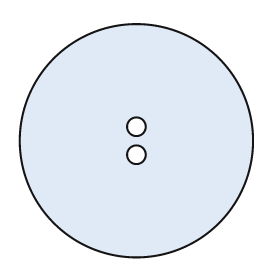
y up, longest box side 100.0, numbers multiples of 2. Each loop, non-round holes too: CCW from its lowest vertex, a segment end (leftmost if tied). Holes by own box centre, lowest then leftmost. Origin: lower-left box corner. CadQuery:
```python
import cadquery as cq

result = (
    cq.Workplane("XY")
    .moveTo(50.0, 50.0)
    .circle(50.0)
    .moveTo(50.0, 44.0)
    .circle(4.0)
    .moveTo(50.0, 56.0)
    .circle(4.0)
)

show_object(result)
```